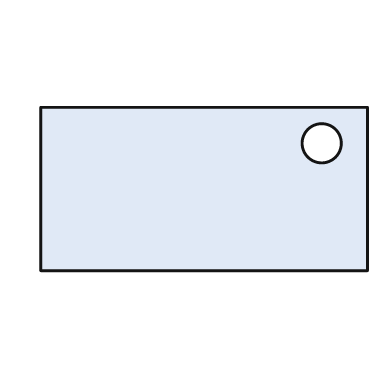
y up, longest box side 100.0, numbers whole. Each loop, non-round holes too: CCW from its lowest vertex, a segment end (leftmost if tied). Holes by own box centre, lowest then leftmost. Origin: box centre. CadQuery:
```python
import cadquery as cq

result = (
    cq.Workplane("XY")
    .moveTo(-50.0, -25.0)
    .lineTo(50.0, -25.0)
    .lineTo(50.0, 25.0)
    .lineTo(-50.0, 25.0)
    .close()
    .moveTo(36.0, 14.0)
    .circle(6.0)
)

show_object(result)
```